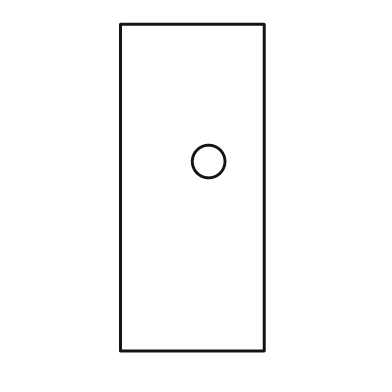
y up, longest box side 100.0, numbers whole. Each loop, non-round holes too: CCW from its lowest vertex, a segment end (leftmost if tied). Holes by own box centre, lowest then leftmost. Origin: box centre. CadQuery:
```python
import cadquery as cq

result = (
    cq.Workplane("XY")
    .moveTo(-22.0, -50.0)
    .lineTo(22.0, -50.0)
    .lineTo(22.0, 50.0)
    .lineTo(-22.0, 50.0)
    .close()
    .moveTo(5.0, 8.0)
    .circle(5.0)
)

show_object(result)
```